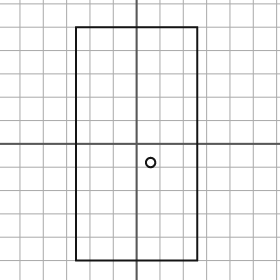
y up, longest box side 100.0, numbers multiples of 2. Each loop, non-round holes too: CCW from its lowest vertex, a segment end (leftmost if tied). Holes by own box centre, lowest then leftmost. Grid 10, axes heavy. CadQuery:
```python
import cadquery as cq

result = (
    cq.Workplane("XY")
    .moveTo(-26.0, -50.0)
    .lineTo(26.0, -50.0)
    .lineTo(26.0, 50.0)
    .lineTo(-26.0, 50.0)
    .close()
    .moveTo(6.0, -8.0)
    .circle(2.0)
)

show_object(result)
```